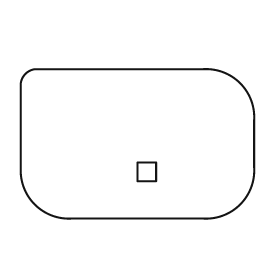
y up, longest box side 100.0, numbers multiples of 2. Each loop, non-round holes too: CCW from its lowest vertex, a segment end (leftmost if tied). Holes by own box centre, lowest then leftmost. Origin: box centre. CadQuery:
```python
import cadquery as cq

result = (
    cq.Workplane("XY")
    .moveTo(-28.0, -32.0)
    .lineTo(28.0, -32.0)
    .threePointArc((44.0, -26.0), (50.0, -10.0))
    .lineTo(50.0, 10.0)
    .threePointArc((44.0, 26.0), (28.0, 32.0))
    .lineTo(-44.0, 32.0)
    .threePointArc((-48.0, 30.0), (-50.0, 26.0))
    .lineTo(-50.0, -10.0)
    .threePointArc((-44.0, -26.0), (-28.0, -32.0))
    .close()
    .moveTo(0.0, -16.0)
    .lineTo(8.0, -16.0)
    .lineTo(8.0, -8.0)
    .lineTo(0.0, -8.0)
    .close()
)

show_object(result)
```